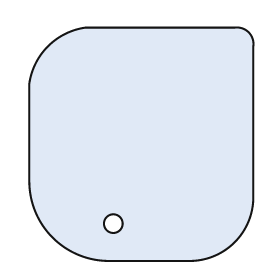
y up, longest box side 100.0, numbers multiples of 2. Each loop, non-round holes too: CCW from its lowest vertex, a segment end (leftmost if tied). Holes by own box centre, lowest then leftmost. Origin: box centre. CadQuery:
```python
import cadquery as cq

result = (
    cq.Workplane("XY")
    .moveTo(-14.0, -50.0)
    .lineTo(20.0, -50.0)
    .threePointArc((40.0, -42.0), (48.0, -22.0))
    .lineTo(48.0, 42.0)
    .threePointArc((46.0, 48.0), (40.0, 50.0))
    .lineTo(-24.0, 50.0)
    .threePointArc((-40.0, 42.0), (-48.0, 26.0))
    .lineTo(-48.0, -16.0)
    .threePointArc((-38.0, -40.0), (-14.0, -50.0))
    .close()
    .moveTo(-12.0, -34.0)
    .circle(4.0)
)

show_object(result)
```